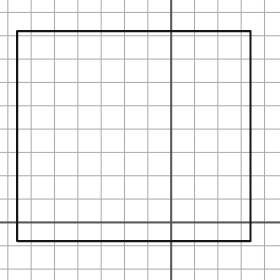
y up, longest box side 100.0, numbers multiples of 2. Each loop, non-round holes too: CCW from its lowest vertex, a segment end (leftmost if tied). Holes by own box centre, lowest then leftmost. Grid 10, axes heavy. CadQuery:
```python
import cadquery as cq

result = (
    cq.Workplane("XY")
    .moveTo(-66.0, -8.0)
    .lineTo(34.0, -8.0)
    .lineTo(34.0, 82.0)
    .lineTo(-66.0, 82.0)
    .close()
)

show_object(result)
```